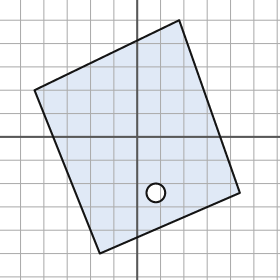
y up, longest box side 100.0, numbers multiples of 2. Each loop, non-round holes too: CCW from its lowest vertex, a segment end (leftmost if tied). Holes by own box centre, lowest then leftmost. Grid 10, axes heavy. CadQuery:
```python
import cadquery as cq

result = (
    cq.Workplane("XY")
    .moveTo(-16.0, -50.0)
    .lineTo(44.0, -24.0)
    .lineTo(18.0, 50.0)
    .lineTo(-44.0, 20.0)
    .close()
    .moveTo(8.0, -24.0)
    .circle(4.0)
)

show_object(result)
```